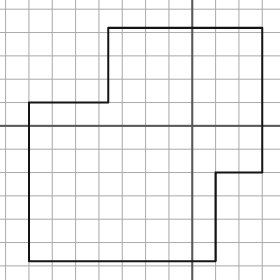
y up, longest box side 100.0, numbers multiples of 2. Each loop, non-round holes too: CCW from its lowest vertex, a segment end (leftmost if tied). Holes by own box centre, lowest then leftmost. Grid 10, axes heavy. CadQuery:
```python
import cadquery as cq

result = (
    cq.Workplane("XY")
    .moveTo(-70.0, -58.0)
    .lineTo(10.0, -58.0)
    .lineTo(10.0, -20.0)
    .lineTo(30.0, -20.0)
    .lineTo(30.0, 42.0)
    .lineTo(-36.0, 42.0)
    .lineTo(-36.0, 10.0)
    .lineTo(-70.0, 10.0)
    .close()
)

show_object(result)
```